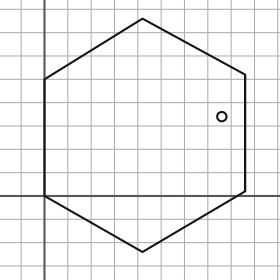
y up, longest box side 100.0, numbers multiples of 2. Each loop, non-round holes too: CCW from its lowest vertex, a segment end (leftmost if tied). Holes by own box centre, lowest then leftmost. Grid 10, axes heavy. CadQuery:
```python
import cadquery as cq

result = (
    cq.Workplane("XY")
    .moveTo(42.0, -24.0)
    .lineTo(86.0, 2.0)
    .lineTo(86.0, 52.0)
    .lineTo(42.0, 76.0)
    .lineTo(0.0, 50.0)
    .lineTo(0.0, 0.0)
    .close()
    .moveTo(76.0, 34.0)
    .circle(2.0)
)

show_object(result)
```